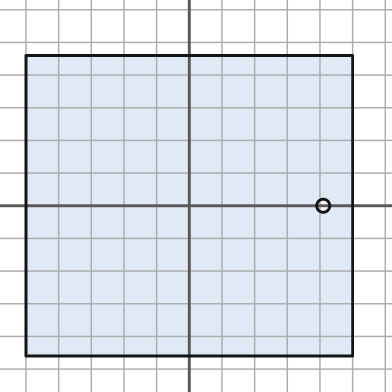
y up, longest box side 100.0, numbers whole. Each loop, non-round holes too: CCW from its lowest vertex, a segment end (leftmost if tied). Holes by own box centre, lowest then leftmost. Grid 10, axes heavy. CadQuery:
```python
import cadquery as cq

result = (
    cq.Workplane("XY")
    .moveTo(-50.0, -46.0)
    .lineTo(50.0, -46.0)
    .lineTo(50.0, 46.0)
    .lineTo(-50.0, 46.0)
    .close()
    .moveTo(41.0, 0.0)
    .circle(2.0)
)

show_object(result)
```